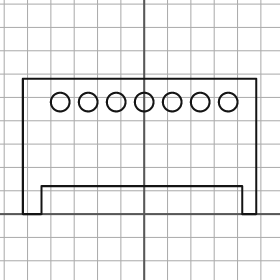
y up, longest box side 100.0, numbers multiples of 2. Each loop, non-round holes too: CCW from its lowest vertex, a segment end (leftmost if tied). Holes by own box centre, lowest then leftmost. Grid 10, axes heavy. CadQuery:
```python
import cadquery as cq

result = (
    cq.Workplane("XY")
    .moveTo(-52.0, 0.0)
    .lineTo(-44.0, 0.0)
    .lineTo(-44.0, 12.0)
    .lineTo(42.0, 12.0)
    .lineTo(42.0, 0.0)
    .lineTo(48.0, 0.0)
    .lineTo(48.0, 58.0)
    .lineTo(-52.0, 58.0)
    .close()
    .moveTo(-36.0, 48.0)
    .circle(4.0)
    .moveTo(-24.0, 48.0)
    .circle(4.0)
    .moveTo(-12.0, 48.0)
    .circle(4.0)
    .moveTo(0.0, 48.0)
    .circle(4.0)
    .moveTo(12.0, 48.0)
    .circle(4.0)
    .moveTo(24.0, 48.0)
    .circle(4.0)
    .moveTo(36.0, 48.0)
    .circle(4.0)
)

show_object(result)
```